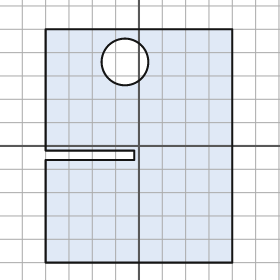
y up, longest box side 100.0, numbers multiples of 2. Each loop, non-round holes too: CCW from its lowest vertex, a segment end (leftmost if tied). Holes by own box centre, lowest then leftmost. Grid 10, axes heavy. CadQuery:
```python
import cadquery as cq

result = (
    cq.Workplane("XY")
    .moveTo(-40.0, -50.0)
    .lineTo(40.0, -50.0)
    .lineTo(40.0, 50.0)
    .lineTo(-40.0, 50.0)
    .lineTo(-40.0, -2.0)
    .lineTo(-2.0, -2.0)
    .lineTo(-2.0, -6.0)
    .lineTo(-40.0, -6.0)
    .close()
    .moveTo(-6.0, 36.0)
    .circle(10.0)
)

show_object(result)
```